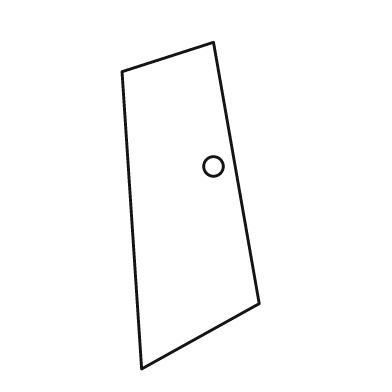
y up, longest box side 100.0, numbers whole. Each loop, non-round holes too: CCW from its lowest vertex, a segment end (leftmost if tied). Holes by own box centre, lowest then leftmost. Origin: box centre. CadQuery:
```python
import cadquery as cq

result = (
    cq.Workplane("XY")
    .moveTo(-15.0, -50.0)
    .lineTo(21.0, -30.0)
    .lineTo(7.0, 50.0)
    .lineTo(-21.0, 41.0)
    .close()
    .moveTo(7.0, 12.0)
    .circle(3.0)
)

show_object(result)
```